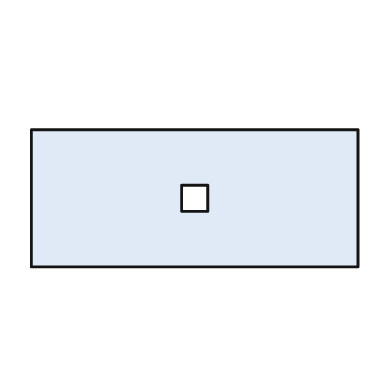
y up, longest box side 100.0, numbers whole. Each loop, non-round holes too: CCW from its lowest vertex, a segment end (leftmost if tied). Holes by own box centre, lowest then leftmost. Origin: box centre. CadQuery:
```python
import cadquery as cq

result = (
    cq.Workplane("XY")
    .moveTo(-50.0, -21.0)
    .lineTo(50.0, -21.0)
    .lineTo(50.0, 21.0)
    .lineTo(-50.0, 21.0)
    .close()
    .moveTo(-4.0, -4.0)
    .lineTo(4.0, -4.0)
    .lineTo(4.0, 4.0)
    .lineTo(-4.0, 4.0)
    .close()
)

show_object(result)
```